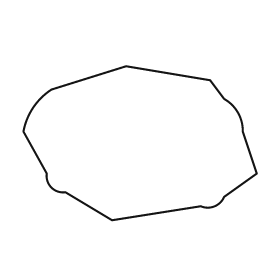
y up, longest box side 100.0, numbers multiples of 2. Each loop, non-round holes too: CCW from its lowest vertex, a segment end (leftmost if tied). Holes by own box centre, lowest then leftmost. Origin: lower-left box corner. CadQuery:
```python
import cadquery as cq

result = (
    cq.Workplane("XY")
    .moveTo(38.0, 0.0)
    .lineTo(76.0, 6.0)
    .threePointArc((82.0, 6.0), (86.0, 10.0))
    .lineTo(100.0, 20.0)
    .lineTo(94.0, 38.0)
    .threePointArc((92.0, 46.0), (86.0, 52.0))
    .lineTo(80.0, 60.0)
    .lineTo(44.0, 66.0)
    .lineTo(12.0, 56.0)
    .threePointArc((4.0, 48.0), (0.0, 38.0))
    .lineTo(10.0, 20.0)
    .threePointArc((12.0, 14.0), (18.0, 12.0))
    .close()
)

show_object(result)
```